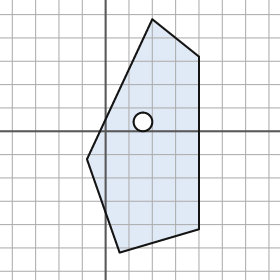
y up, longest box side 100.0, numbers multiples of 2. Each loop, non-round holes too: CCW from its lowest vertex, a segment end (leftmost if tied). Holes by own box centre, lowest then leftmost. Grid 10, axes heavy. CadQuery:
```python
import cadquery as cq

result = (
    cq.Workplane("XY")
    .moveTo(6.0, -52.0)
    .lineTo(40.0, -42.0)
    .lineTo(40.0, 32.0)
    .lineTo(20.0, 48.0)
    .lineTo(-8.0, -12.0)
    .close()
    .moveTo(16.0, 4.0)
    .circle(4.0)
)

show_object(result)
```